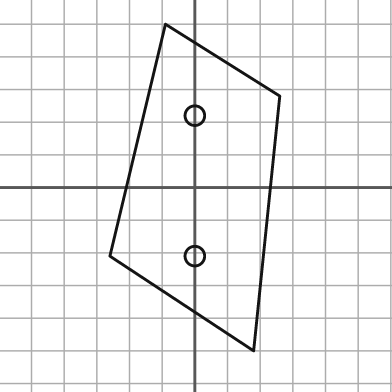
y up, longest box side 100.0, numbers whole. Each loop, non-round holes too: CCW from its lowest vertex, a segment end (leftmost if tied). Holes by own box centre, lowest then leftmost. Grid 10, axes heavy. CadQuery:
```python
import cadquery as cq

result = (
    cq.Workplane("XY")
    .moveTo(18.0, -50.0)
    .lineTo(26.0, 28.0)
    .lineTo(-9.0, 50.0)
    .lineTo(-26.0, -21.0)
    .close()
    .moveTo(0.0, -21.0)
    .circle(3.0)
    .moveTo(0.0, 22.0)
    .circle(3.0)
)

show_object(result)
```